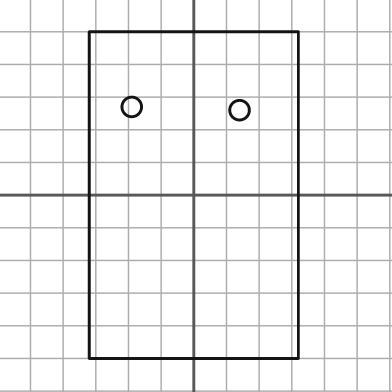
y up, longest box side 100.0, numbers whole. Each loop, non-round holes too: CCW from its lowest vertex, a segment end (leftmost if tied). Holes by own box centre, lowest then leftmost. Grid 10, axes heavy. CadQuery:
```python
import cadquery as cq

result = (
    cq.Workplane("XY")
    .moveTo(-32.0, -50.0)
    .lineTo(32.0, -50.0)
    .lineTo(32.0, 50.0)
    .lineTo(-32.0, 50.0)
    .close()
    .moveTo(14.0, 26.0)
    .circle(3.0)
    .moveTo(-19.0, 27.0)
    .circle(3.0)
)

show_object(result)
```